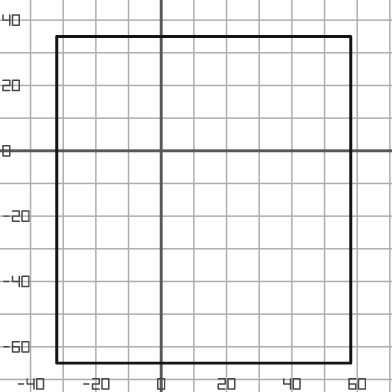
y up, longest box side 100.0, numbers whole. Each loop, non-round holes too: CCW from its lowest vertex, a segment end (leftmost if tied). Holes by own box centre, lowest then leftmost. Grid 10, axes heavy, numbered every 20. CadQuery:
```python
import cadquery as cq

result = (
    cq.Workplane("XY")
    .moveTo(-32.0, -65.0)
    .lineTo(58.0, -65.0)
    .lineTo(58.0, 35.0)
    .lineTo(-32.0, 35.0)
    .close()
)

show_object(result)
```